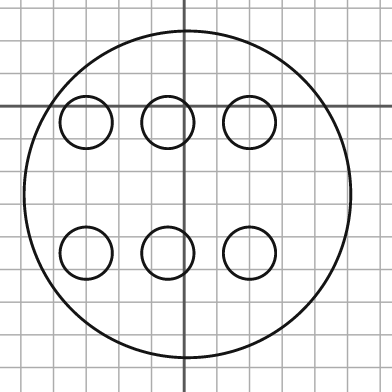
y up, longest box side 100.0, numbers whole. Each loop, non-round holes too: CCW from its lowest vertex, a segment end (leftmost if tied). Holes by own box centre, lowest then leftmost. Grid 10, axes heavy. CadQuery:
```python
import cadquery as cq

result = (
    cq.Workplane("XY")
    .moveTo(1.0, -27.0)
    .circle(50.0)
    .moveTo(-30.0, -45.0)
    .circle(8.0)
    .moveTo(-5.0, -45.0)
    .circle(8.0)
    .moveTo(20.0, -45.0)
    .circle(8.0)
    .moveTo(-30.0, -5.0)
    .circle(8.0)
    .moveTo(-5.0, -5.0)
    .circle(8.0)
    .moveTo(20.0, -5.0)
    .circle(8.0)
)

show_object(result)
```